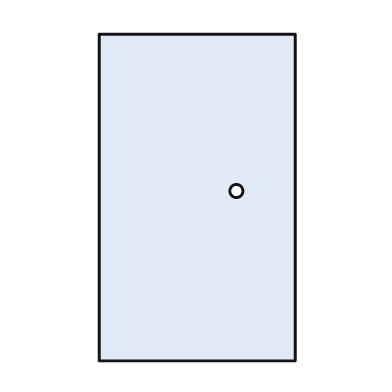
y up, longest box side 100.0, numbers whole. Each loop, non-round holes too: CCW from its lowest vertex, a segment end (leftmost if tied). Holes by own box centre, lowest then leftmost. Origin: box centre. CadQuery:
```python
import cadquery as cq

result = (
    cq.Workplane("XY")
    .moveTo(-30.0, -50.0)
    .lineTo(30.0, -50.0)
    .lineTo(30.0, 50.0)
    .lineTo(-30.0, 50.0)
    .close()
    .moveTo(12.0, 2.0)
    .circle(2.0)
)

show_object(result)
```